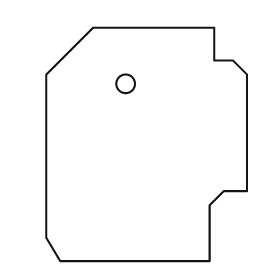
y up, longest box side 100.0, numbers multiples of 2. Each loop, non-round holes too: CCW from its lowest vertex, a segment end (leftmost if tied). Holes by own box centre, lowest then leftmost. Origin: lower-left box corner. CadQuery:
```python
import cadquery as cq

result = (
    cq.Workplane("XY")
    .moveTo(6.0, 0.0)
    .lineTo(70.0, 0.0)
    .lineTo(70.0, 24.0)
    .lineTo(76.0, 30.0)
    .lineTo(86.0, 30.0)
    .lineTo(86.0, 80.0)
    .lineTo(80.0, 86.0)
    .lineTo(72.0, 86.0)
    .lineTo(72.0, 100.0)
    .lineTo(20.0, 100.0)
    .lineTo(0.0, 80.0)
    .lineTo(0.0, 10.0)
    .close()
    .moveTo(34.0, 76.0)
    .circle(4.0)
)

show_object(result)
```